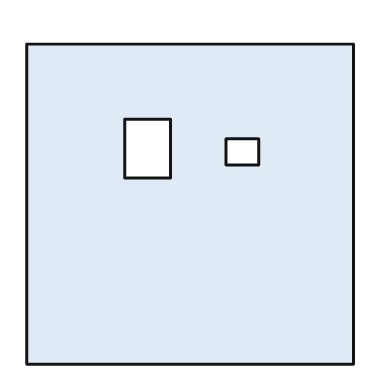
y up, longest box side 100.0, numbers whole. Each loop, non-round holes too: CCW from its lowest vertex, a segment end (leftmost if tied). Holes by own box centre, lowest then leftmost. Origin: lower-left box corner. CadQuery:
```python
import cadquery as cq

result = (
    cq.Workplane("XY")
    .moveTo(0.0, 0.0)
    .lineTo(100.0, 0.0)
    .lineTo(100.0, 98.0)
    .lineTo(0.0, 98.0)
    .close()
    .moveTo(61.0, 61.0)
    .lineTo(71.0, 61.0)
    .lineTo(71.0, 69.0)
    .lineTo(61.0, 69.0)
    .close()
    .moveTo(30.0, 57.0)
    .lineTo(44.0, 57.0)
    .lineTo(44.0, 75.0)
    .lineTo(30.0, 75.0)
    .close()
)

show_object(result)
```